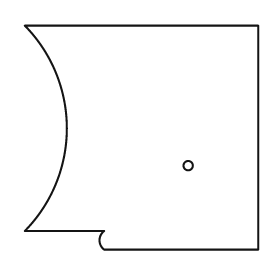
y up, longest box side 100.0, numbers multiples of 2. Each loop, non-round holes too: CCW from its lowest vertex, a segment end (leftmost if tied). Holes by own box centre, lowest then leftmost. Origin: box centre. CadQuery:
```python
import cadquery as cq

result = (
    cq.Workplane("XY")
    .moveTo(-16.0, -48.0)
    .lineTo(50.0, -48.0)
    .lineTo(50.0, 48.0)
    .lineTo(-50.0, 48.0)
    .threePointArc((-32.0, 4.0), (-50.0, -40.0))
    .lineTo(-16.0, -40.0)
    .threePointArc((-18.0, -44.0), (-16.0, -48.0))
    .close()
    .moveTo(20.0, -12.0)
    .circle(2.0)
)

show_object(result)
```